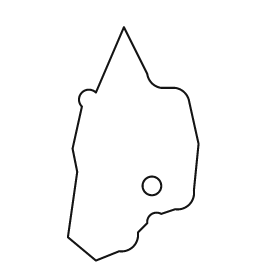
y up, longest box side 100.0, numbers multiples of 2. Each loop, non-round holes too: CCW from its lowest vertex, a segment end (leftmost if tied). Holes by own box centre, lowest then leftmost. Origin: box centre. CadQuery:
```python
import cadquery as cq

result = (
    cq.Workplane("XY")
    .moveTo(-16.0, -50.0)
    .lineTo(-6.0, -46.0)
    .threePointArc((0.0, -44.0), (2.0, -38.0))
    .lineTo(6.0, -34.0)
    .threePointArc((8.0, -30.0), (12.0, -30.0))
    .lineTo(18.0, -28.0)
    .threePointArc((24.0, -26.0), (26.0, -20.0))
    .lineTo(28.0, 0.0)
    .lineTo(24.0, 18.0)
    .threePointArc((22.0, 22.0), (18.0, 24.0))
    .lineTo(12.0, 24.0)
    .threePointArc((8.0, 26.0), (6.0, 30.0))
    .lineTo(-4.0, 50.0)
    .lineTo(-16.0, 22.0)
    .threePointArc((-22.0, 22.0), (-22.0, 16.0))
    .lineTo(-26.0, -2.0)
    .lineTo(-24.0, -12.0)
    .lineTo(-28.0, -40.0)
    .close()
    .moveTo(8.0, -18.0)
    .circle(4.0)
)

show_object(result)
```